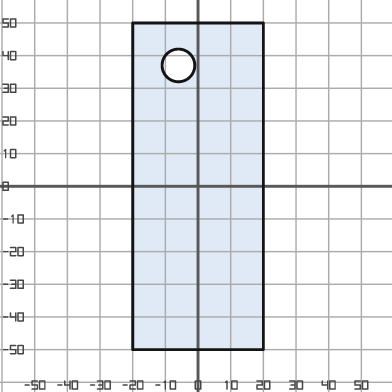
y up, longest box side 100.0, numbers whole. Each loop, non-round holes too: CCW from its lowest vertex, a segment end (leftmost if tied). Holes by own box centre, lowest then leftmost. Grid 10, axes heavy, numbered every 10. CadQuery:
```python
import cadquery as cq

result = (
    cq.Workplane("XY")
    .moveTo(-20.0, -50.0)
    .lineTo(20.0, -50.0)
    .lineTo(20.0, 50.0)
    .lineTo(-20.0, 50.0)
    .close()
    .moveTo(-6.0, 37.0)
    .circle(5.0)
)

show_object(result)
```